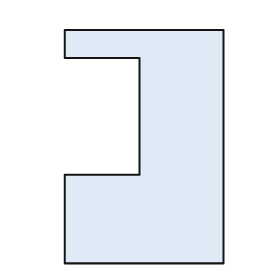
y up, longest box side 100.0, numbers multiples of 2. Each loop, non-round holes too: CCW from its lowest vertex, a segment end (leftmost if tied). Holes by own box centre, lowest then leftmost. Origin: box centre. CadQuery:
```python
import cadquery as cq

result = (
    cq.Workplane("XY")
    .moveTo(-34.0, -50.0)
    .lineTo(34.0, -50.0)
    .lineTo(34.0, 50.0)
    .lineTo(-34.0, 50.0)
    .lineTo(-34.0, 38.0)
    .lineTo(-2.0, 38.0)
    .lineTo(-2.0, -12.0)
    .lineTo(-34.0, -12.0)
    .close()
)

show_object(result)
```